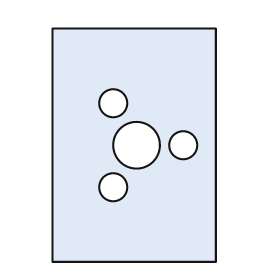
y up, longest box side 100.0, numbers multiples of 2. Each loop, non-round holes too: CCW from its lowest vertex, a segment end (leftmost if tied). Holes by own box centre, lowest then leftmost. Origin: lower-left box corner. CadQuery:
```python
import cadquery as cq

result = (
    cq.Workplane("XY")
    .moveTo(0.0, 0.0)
    .lineTo(70.0, 0.0)
    .lineTo(70.0, 100.0)
    .lineTo(0.0, 100.0)
    .close()
    .moveTo(26.0, 32.0)
    .circle(6.0)
    .moveTo(36.0, 50.0)
    .circle(10.0)
    .moveTo(56.0, 50.0)
    .circle(6.0)
    .moveTo(26.0, 68.0)
    .circle(6.0)
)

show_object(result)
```